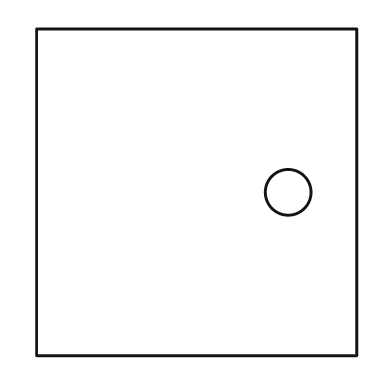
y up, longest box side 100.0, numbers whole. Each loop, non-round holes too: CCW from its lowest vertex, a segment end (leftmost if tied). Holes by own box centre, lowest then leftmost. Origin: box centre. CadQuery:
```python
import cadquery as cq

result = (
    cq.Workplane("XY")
    .moveTo(-49.0, -50.0)
    .lineTo(49.0, -50.0)
    .lineTo(49.0, 50.0)
    .lineTo(-49.0, 50.0)
    .close()
    .moveTo(28.0, 0.0)
    .circle(7.0)
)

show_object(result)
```